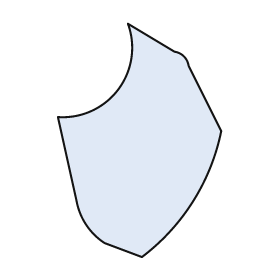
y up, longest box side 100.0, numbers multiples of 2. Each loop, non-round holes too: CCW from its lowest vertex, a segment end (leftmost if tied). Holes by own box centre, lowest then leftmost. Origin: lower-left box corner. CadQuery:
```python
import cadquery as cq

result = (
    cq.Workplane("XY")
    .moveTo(36.0, 0.0)
    .threePointArc((58.0, 24.0), (70.0, 54.0))
    .lineTo(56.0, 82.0)
    .threePointArc((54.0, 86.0), (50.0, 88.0))
    .lineTo(30.0, 100.0)
    .threePointArc((26.0, 72.0), (0.0, 60.0))
    .lineTo(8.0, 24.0)
    .threePointArc((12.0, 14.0), (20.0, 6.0))
    .close()
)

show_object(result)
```